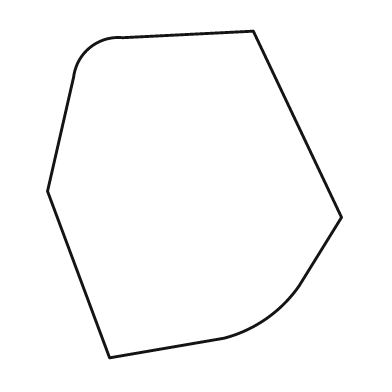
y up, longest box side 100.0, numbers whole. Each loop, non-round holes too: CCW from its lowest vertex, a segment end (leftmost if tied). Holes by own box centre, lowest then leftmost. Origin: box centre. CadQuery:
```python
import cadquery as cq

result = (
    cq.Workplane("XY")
    .moveTo(-26.0, -50.0)
    .lineTo(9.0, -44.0)
    .threePointArc((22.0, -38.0), (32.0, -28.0))
    .lineTo(45.0, -7.0)
    .lineTo(18.0, 50.0)
    .lineTo(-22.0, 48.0)
    .threePointArc((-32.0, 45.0), (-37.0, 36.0))
    .lineTo(-45.0, 1.0)
    .close()
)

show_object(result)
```